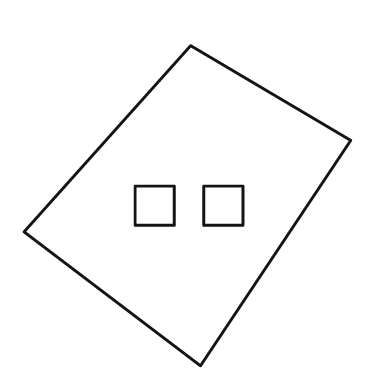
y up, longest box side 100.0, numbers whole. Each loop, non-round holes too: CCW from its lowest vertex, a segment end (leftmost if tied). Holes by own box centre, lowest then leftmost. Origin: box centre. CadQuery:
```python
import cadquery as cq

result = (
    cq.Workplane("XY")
    .moveTo(4.0, -49.0)
    .lineTo(50.0, 20.0)
    .lineTo(1.0, 49.0)
    .lineTo(-50.0, -8.0)
    .close()
    .moveTo(-16.0, -6.0)
    .lineTo(-4.0, -6.0)
    .lineTo(-4.0, 6.0)
    .lineTo(-16.0, 6.0)
    .close()
    .moveTo(5.0, -6.0)
    .lineTo(17.0, -6.0)
    .lineTo(17.0, 6.0)
    .lineTo(5.0, 6.0)
    .close()
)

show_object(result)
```